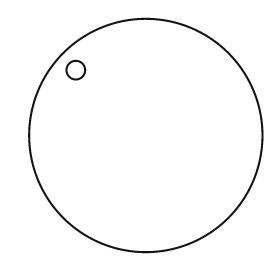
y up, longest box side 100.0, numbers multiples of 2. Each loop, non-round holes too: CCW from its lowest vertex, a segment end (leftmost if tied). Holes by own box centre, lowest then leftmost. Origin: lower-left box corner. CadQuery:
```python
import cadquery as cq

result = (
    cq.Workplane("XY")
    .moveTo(50.0, 50.0)
    .circle(50.0)
    .moveTo(20.0, 78.0)
    .circle(4.0)
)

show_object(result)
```